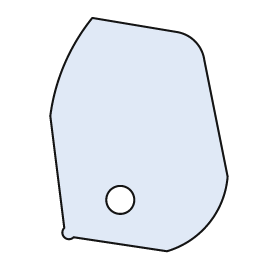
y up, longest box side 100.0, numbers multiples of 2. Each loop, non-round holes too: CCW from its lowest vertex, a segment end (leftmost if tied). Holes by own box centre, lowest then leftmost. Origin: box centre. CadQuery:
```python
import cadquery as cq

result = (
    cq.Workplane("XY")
    .moveTo(12.0, -50.0)
    .threePointArc((30.0, -38.0), (38.0, -18.0))
    .lineTo(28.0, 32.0)
    .threePointArc((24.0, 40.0), (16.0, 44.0))
    .lineTo(-20.0, 50.0)
    .threePointArc((-32.0, 30.0), (-38.0, 8.0))
    .lineTo(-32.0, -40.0)
    .threePointArc((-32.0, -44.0), (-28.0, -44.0))
    .close()
    .moveTo(-8.0, -28.0)
    .circle(6.0)
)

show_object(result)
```